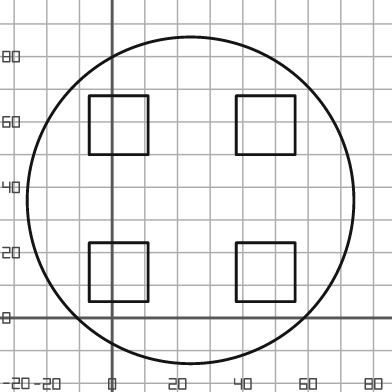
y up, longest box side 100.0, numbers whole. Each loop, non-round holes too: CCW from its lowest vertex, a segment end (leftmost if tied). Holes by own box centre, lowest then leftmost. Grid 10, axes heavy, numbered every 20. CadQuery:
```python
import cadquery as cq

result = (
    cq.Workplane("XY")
    .moveTo(24.0, 36.0)
    .circle(50.0)
    .moveTo(-7.0, 5.0)
    .lineTo(11.0, 5.0)
    .lineTo(11.0, 23.0)
    .lineTo(-7.0, 23.0)
    .close()
    .moveTo(38.0, 5.0)
    .lineTo(56.0, 5.0)
    .lineTo(56.0, 23.0)
    .lineTo(38.0, 23.0)
    .close()
    .moveTo(-7.0, 50.0)
    .lineTo(11.0, 50.0)
    .lineTo(11.0, 68.0)
    .lineTo(-7.0, 68.0)
    .close()
    .moveTo(38.0, 50.0)
    .lineTo(56.0, 50.0)
    .lineTo(56.0, 68.0)
    .lineTo(38.0, 68.0)
    .close()
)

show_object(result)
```